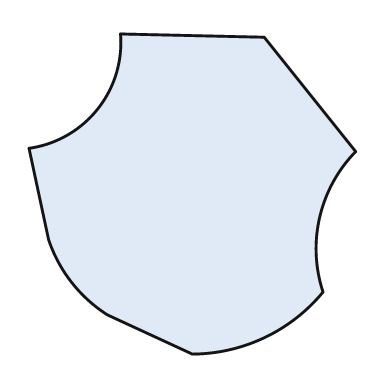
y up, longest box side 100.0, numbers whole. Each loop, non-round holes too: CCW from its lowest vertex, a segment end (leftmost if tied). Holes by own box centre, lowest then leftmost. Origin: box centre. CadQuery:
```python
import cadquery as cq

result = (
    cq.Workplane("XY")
    .moveTo(0.0, -49.0)
    .threePointArc((22.0, -44.0), (40.0, -30.0))
    .threePointArc((39.0, -7.0), (50.0, 13.0))
    .lineTo(22.0, 48.0)
    .lineTo(-22.0, 49.0)
    .threePointArc((-29.0, 26.0), (-50.0, 14.0))
    .lineTo(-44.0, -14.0)
    .threePointArc((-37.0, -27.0), (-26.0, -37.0))
    .close()
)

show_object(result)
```